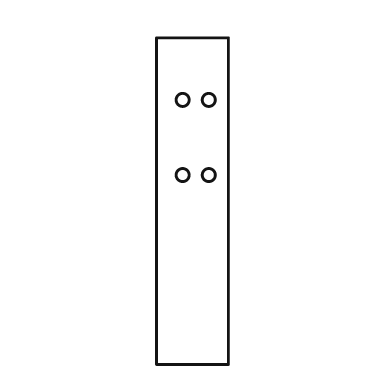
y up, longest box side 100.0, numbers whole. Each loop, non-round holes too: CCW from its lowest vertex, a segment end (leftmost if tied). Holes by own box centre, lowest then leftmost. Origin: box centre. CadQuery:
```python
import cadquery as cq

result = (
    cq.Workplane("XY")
    .moveTo(-11.0, -50.0)
    .lineTo(11.0, -50.0)
    .lineTo(11.0, 50.0)
    .lineTo(-11.0, 50.0)
    .close()
    .moveTo(-3.0, 8.0)
    .circle(2.0)
    .moveTo(5.0, 8.0)
    .circle(2.0)
    .moveTo(-3.0, 31.0)
    .circle(2.0)
    .moveTo(5.0, 31.0)
    .circle(2.0)
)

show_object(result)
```